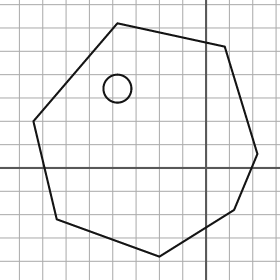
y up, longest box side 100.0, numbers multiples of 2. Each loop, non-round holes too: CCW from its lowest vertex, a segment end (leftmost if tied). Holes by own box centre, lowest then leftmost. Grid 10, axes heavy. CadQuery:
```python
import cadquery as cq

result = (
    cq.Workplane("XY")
    .moveTo(-20.0, -38.0)
    .lineTo(12.0, -18.0)
    .lineTo(22.0, 6.0)
    .lineTo(8.0, 52.0)
    .lineTo(-38.0, 62.0)
    .lineTo(-74.0, 20.0)
    .lineTo(-64.0, -22.0)
    .close()
    .moveTo(-38.0, 34.0)
    .circle(6.0)
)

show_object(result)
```